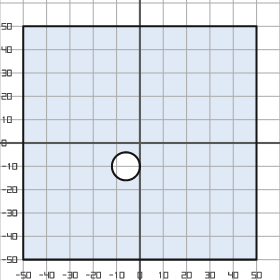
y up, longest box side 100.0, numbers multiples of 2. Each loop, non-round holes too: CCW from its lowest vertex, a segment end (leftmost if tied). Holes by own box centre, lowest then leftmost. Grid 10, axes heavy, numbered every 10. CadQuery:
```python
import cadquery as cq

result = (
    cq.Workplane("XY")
    .moveTo(-50.0, -50.0)
    .lineTo(50.0, -50.0)
    .lineTo(50.0, 50.0)
    .lineTo(-50.0, 50.0)
    .close()
    .moveTo(-6.0, -10.0)
    .circle(6.0)
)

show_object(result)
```